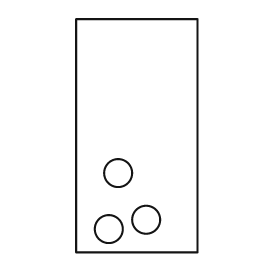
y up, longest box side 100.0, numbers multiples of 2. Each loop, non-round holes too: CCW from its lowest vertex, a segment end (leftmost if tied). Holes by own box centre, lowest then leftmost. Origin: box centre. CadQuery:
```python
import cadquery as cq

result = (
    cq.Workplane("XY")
    .moveTo(-26.0, -50.0)
    .lineTo(26.0, -50.0)
    .lineTo(26.0, 50.0)
    .lineTo(-26.0, 50.0)
    .close()
    .moveTo(-12.0, -40.0)
    .circle(6.0)
    .moveTo(4.0, -36.0)
    .circle(6.0)
    .moveTo(-8.0, -16.0)
    .circle(6.0)
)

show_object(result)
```